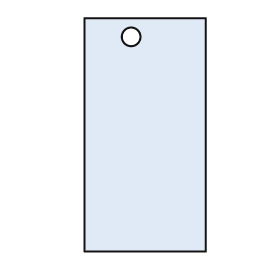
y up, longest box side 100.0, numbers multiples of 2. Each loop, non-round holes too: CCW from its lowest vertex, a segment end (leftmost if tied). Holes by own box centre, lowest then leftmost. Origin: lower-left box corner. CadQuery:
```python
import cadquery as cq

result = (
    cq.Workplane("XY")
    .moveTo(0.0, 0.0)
    .lineTo(52.0, 0.0)
    .lineTo(52.0, 100.0)
    .lineTo(0.0, 100.0)
    .close()
    .moveTo(20.0, 92.0)
    .circle(4.0)
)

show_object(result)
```